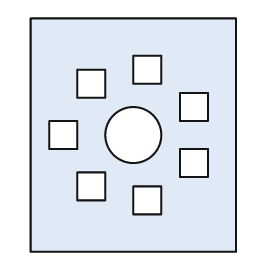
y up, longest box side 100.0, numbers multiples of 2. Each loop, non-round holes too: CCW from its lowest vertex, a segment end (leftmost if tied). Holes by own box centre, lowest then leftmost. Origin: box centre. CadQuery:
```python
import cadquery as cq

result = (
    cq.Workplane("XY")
    .moveTo(-44.0, -50.0)
    .lineTo(44.0, -50.0)
    .lineTo(44.0, 50.0)
    .lineTo(-44.0, 50.0)
    .close()
    .moveTo(0.0, -34.0)
    .lineTo(12.0, -34.0)
    .lineTo(12.0, -22.0)
    .lineTo(0.0, -22.0)
    .close()
    .moveTo(-24.0, -28.0)
    .lineTo(-12.0, -28.0)
    .lineTo(-12.0, -16.0)
    .lineTo(-24.0, -16.0)
    .close()
    .moveTo(20.0, -18.0)
    .lineTo(32.0, -18.0)
    .lineTo(32.0, -6.0)
    .lineTo(20.0, -6.0)
    .close()
    .moveTo(-36.0, -6.0)
    .lineTo(-24.0, -6.0)
    .lineTo(-24.0, 6.0)
    .lineTo(-36.0, 6.0)
    .close()
    .moveTo(0.0, 0.0)
    .circle(12.0)
    .moveTo(20.0, 6.0)
    .lineTo(32.0, 6.0)
    .lineTo(32.0, 18.0)
    .lineTo(20.0, 18.0)
    .close()
    .moveTo(-24.0, 16.0)
    .lineTo(-12.0, 16.0)
    .lineTo(-12.0, 28.0)
    .lineTo(-24.0, 28.0)
    .close()
    .moveTo(0.0, 22.0)
    .lineTo(12.0, 22.0)
    .lineTo(12.0, 34.0)
    .lineTo(0.0, 34.0)
    .close()
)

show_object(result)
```